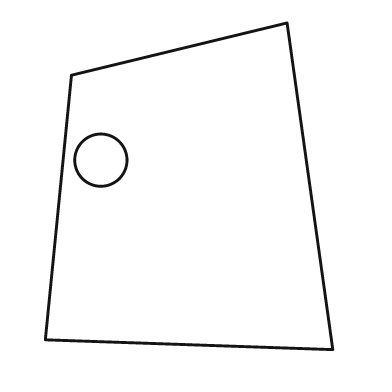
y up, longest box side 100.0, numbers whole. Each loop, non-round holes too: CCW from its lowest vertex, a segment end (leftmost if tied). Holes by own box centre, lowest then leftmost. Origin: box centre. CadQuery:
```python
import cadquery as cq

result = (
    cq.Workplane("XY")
    .moveTo(44.0, -50.0)
    .lineTo(30.0, 50.0)
    .lineTo(-36.0, 34.0)
    .lineTo(-44.0, -47.0)
    .close()
    .moveTo(-27.0, 8.0)
    .circle(8.0)
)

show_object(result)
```